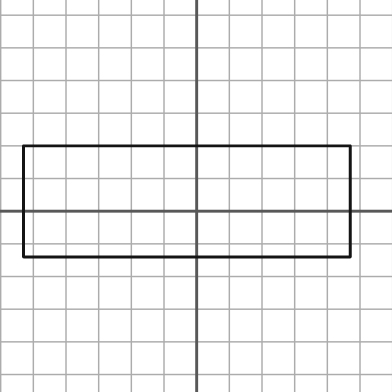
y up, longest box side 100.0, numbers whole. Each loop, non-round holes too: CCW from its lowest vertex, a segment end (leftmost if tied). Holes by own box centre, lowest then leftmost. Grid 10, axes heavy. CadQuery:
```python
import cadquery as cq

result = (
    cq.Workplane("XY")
    .moveTo(-53.0, -14.0)
    .lineTo(47.0, -14.0)
    .lineTo(47.0, 20.0)
    .lineTo(-53.0, 20.0)
    .close()
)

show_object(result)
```